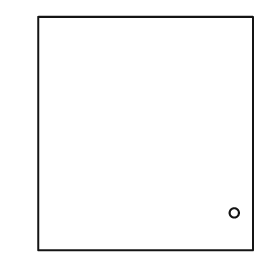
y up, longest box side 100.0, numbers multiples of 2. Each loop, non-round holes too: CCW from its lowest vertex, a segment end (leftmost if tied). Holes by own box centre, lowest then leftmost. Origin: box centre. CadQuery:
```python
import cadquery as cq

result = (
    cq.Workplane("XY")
    .moveTo(-46.0, -50.0)
    .lineTo(46.0, -50.0)
    .lineTo(46.0, 50.0)
    .lineTo(-46.0, 50.0)
    .close()
    .moveTo(38.0, -34.0)
    .circle(2.0)
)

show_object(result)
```